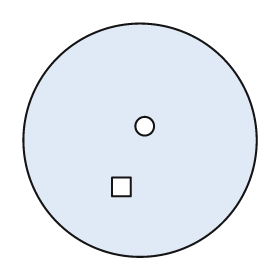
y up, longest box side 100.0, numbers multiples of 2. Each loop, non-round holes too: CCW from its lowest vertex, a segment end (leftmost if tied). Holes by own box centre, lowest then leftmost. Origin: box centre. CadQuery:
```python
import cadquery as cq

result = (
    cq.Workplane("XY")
    .moveTo(0.0, 0.0)
    .circle(50.0)
    .moveTo(-12.0, -24.0)
    .lineTo(-4.0, -24.0)
    .lineTo(-4.0, -16.0)
    .lineTo(-12.0, -16.0)
    .close()
    .moveTo(2.0, 6.0)
    .circle(4.0)
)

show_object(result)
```